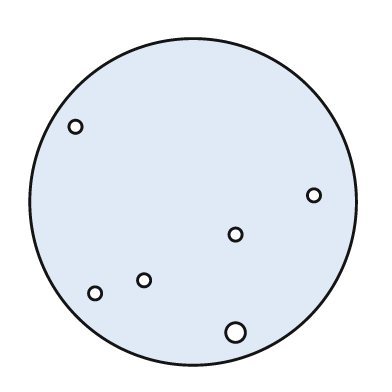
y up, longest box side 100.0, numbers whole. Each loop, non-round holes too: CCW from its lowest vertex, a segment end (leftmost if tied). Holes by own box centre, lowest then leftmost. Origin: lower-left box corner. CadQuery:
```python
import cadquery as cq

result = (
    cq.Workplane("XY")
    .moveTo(50.0, 50.0)
    .circle(50.0)
    .moveTo(63.0, 10.0)
    .circle(3.0)
    .moveTo(20.0, 22.0)
    .circle(2.0)
    .moveTo(35.0, 26.0)
    .circle(2.0)
    .moveTo(63.0, 40.0)
    .circle(2.0)
    .moveTo(87.0, 52.0)
    .circle(2.0)
    .moveTo(14.0, 73.0)
    .circle(2.0)
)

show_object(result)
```